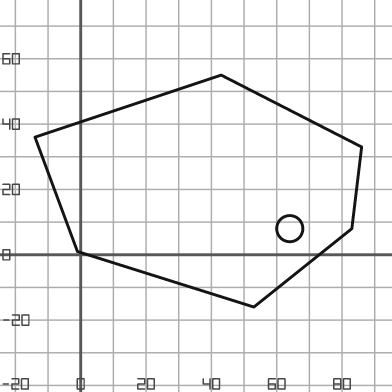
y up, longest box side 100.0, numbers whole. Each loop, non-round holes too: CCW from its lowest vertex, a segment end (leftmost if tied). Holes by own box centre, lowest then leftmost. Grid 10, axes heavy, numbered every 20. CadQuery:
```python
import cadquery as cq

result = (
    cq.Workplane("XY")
    .moveTo(53.0, -16.0)
    .lineTo(83.0, 8.0)
    .lineTo(86.0, 33.0)
    .lineTo(43.0, 55.0)
    .lineTo(-14.0, 36.0)
    .lineTo(-1.0, 1.0)
    .close()
    .moveTo(64.0, 8.0)
    .circle(4.0)
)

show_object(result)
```